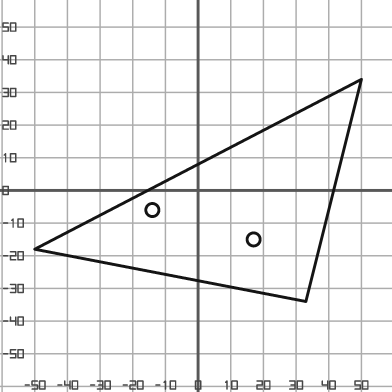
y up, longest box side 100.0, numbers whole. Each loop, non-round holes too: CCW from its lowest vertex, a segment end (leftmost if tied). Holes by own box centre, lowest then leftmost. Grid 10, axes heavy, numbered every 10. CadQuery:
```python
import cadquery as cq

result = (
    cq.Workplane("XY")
    .moveTo(33.0, -34.0)
    .lineTo(50.0, 34.0)
    .lineTo(-50.0, -18.0)
    .close()
    .moveTo(17.0, -15.0)
    .circle(2.0)
    .moveTo(-14.0, -6.0)
    .circle(2.0)
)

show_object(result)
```